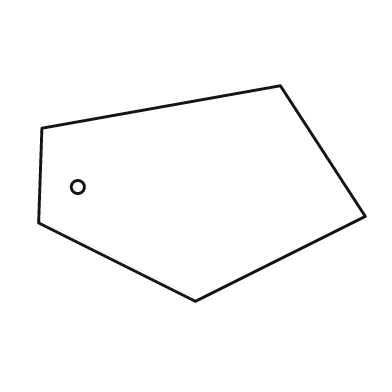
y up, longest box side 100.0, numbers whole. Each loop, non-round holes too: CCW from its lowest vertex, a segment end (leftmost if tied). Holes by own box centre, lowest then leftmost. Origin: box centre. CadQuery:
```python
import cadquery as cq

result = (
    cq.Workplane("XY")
    .moveTo(-2.0, -33.0)
    .lineTo(50.0, -7.0)
    .lineTo(24.0, 33.0)
    .lineTo(-49.0, 20.0)
    .lineTo(-50.0, -9.0)
    .close()
    .moveTo(-38.0, 2.0)
    .circle(2.0)
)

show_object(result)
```